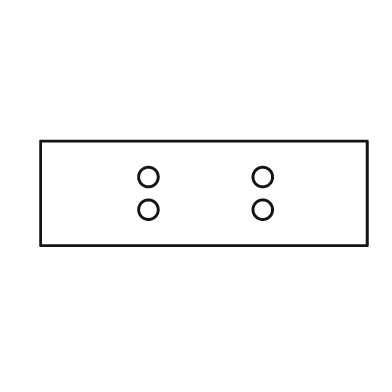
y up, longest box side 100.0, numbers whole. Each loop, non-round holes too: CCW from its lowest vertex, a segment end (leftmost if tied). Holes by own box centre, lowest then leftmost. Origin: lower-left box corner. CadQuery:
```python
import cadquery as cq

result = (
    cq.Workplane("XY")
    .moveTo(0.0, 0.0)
    .lineTo(100.0, 0.0)
    .lineTo(100.0, 32.0)
    .lineTo(0.0, 32.0)
    .close()
    .moveTo(33.0, 11.0)
    .circle(3.0)
    .moveTo(68.0, 11.0)
    .circle(3.0)
    .moveTo(33.0, 21.0)
    .circle(3.0)
    .moveTo(68.0, 21.0)
    .circle(3.0)
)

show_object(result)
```